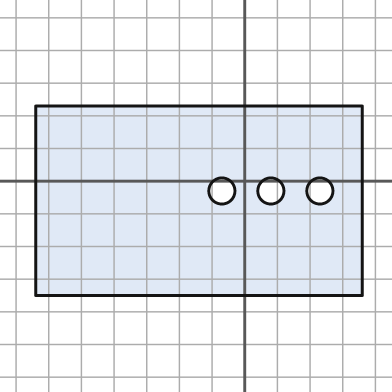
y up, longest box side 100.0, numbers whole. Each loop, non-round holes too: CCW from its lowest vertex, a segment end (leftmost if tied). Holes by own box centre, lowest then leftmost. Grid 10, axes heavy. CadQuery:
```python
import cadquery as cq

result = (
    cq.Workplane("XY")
    .moveTo(-64.0, -35.0)
    .lineTo(36.0, -35.0)
    .lineTo(36.0, 23.0)
    .lineTo(-64.0, 23.0)
    .close()
    .moveTo(-7.0, -3.0)
    .circle(4.0)
    .moveTo(8.0, -3.0)
    .circle(4.0)
    .moveTo(23.0, -3.0)
    .circle(4.0)
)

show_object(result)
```